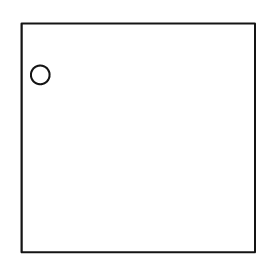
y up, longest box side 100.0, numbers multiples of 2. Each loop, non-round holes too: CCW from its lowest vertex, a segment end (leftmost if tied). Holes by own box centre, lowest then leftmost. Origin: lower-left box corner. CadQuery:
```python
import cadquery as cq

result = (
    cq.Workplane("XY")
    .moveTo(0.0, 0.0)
    .lineTo(100.0, 0.0)
    .lineTo(100.0, 98.0)
    .lineTo(0.0, 98.0)
    .close()
    .moveTo(8.0, 76.0)
    .circle(4.0)
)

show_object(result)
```